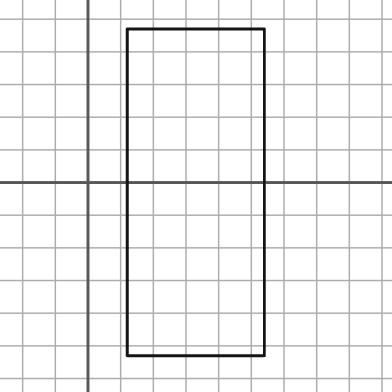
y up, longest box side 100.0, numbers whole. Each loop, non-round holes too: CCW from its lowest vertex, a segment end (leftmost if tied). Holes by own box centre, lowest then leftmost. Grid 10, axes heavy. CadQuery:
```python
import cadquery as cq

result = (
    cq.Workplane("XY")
    .moveTo(12.0, -53.0)
    .lineTo(54.0, -53.0)
    .lineTo(54.0, 47.0)
    .lineTo(12.0, 47.0)
    .close()
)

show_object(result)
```